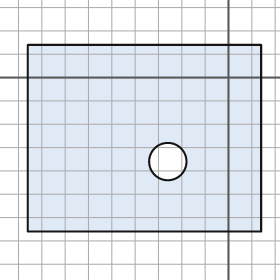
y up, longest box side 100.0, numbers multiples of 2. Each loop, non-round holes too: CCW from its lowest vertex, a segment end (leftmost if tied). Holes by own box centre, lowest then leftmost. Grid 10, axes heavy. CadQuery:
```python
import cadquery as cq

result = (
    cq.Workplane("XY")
    .moveTo(-86.0, -66.0)
    .lineTo(14.0, -66.0)
    .lineTo(14.0, 14.0)
    .lineTo(-86.0, 14.0)
    .close()
    .moveTo(-26.0, -36.0)
    .circle(8.0)
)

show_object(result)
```